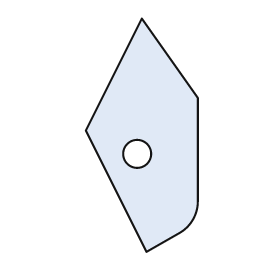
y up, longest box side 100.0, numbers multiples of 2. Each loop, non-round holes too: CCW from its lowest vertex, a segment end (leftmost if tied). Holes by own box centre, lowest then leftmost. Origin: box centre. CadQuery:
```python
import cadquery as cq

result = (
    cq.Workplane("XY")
    .moveTo(2.0, -50.0)
    .lineTo(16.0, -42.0)
    .threePointArc((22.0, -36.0), (24.0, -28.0))
    .lineTo(24.0, 16.0)
    .lineTo(0.0, 50.0)
    .lineTo(-24.0, 2.0)
    .close()
    .moveTo(-2.0, -8.0)
    .circle(6.0)
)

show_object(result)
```